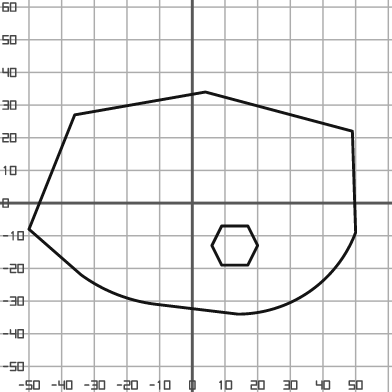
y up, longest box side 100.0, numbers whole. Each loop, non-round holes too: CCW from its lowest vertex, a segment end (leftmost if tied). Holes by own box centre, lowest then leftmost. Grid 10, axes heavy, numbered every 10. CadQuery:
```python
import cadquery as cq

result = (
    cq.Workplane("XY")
    .moveTo(14.0, -34.0)
    .threePointArc((36.0, -27.0), (50.0, -9.0))
    .lineTo(49.0, 22.0)
    .lineTo(4.0, 34.0)
    .lineTo(-36.0, 27.0)
    .lineTo(-50.0, -8.0)
    .lineTo(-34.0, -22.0)
    .threePointArc((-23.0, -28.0), (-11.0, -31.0))
    .close()
    .moveTo(9.0, -19.0)
    .lineTo(17.0, -19.0)
    .lineTo(20.0, -13.0)
    .lineTo(17.0, -7.0)
    .lineTo(9.0, -7.0)
    .lineTo(6.0, -13.0)
    .close()
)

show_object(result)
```